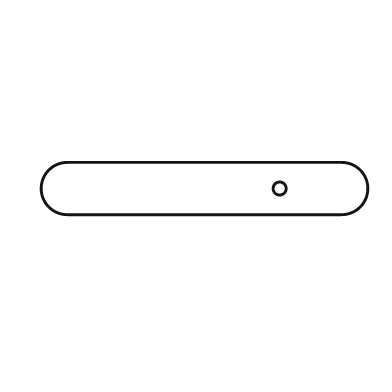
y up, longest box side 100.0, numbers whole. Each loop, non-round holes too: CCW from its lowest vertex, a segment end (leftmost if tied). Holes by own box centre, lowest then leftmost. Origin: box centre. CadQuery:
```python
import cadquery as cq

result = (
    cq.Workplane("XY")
    .moveTo(-42.0, -8.0)
    .lineTo(42.0, -8.0)
    .threePointArc((50.0, 0.0), (42.0, 8.0))
    .lineTo(-42.0, 8.0)
    .threePointArc((-50.0, 0.0), (-42.0, -8.0))
    .close()
    .moveTo(23.0, 0.0)
    .circle(2.0)
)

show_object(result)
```